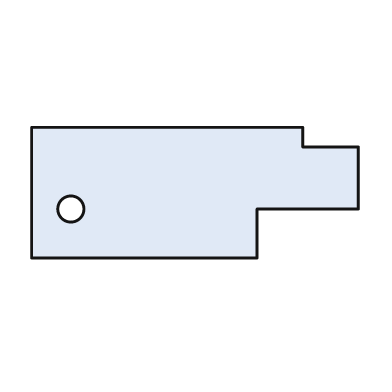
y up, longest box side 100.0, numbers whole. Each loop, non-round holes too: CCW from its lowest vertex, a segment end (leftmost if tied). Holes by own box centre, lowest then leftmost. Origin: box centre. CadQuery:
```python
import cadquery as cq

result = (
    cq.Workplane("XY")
    .moveTo(-50.0, -20.0)
    .lineTo(19.0, -20.0)
    .lineTo(19.0, -5.0)
    .lineTo(50.0, -5.0)
    .lineTo(50.0, 14.0)
    .lineTo(33.0, 14.0)
    .lineTo(33.0, 20.0)
    .lineTo(-50.0, 20.0)
    .close()
    .moveTo(-38.0, -5.0)
    .circle(4.0)
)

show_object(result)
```